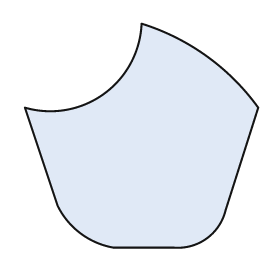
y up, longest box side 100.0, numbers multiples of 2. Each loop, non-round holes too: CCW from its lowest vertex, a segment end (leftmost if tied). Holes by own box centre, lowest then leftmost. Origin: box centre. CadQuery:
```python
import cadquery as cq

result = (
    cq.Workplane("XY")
    .moveTo(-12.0, -48.0)
    .lineTo(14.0, -48.0)
    .threePointArc((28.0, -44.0), (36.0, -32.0))
    .lineTo(50.0, 12.0)
    .threePointArc((28.0, 34.0), (0.0, 48.0))
    .threePointArc((-16.0, 18.0), (-50.0, 12.0))
    .lineTo(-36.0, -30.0)
    .threePointArc((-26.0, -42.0), (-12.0, -48.0))
    .close()
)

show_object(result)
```